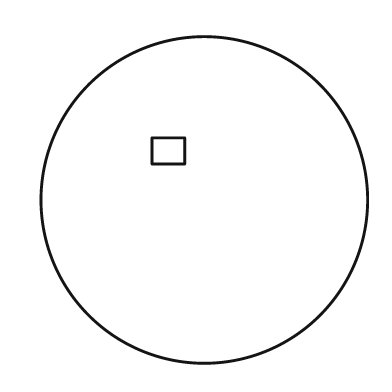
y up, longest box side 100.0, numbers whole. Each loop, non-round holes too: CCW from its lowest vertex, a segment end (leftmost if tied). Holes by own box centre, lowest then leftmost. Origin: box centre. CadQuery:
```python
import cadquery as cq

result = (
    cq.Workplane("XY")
    .moveTo(0.0, 0.0)
    .circle(50.0)
    .moveTo(-16.0, 11.0)
    .lineTo(-6.0, 11.0)
    .lineTo(-6.0, 19.0)
    .lineTo(-16.0, 19.0)
    .close()
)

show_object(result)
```